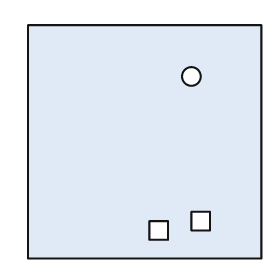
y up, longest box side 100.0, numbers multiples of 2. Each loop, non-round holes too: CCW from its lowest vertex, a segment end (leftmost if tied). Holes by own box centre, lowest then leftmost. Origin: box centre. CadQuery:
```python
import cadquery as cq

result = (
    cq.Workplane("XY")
    .moveTo(-50.0, -50.0)
    .lineTo(50.0, -50.0)
    .lineTo(50.0, 50.0)
    .lineTo(-50.0, 50.0)
    .close()
    .moveTo(2.0, -42.0)
    .lineTo(10.0, -42.0)
    .lineTo(10.0, -34.0)
    .lineTo(2.0, -34.0)
    .close()
    .moveTo(20.0, -38.0)
    .lineTo(28.0, -38.0)
    .lineTo(28.0, -30.0)
    .lineTo(20.0, -30.0)
    .close()
    .moveTo(20.0, 28.0)
    .circle(4.0)
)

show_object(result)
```